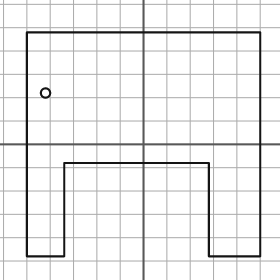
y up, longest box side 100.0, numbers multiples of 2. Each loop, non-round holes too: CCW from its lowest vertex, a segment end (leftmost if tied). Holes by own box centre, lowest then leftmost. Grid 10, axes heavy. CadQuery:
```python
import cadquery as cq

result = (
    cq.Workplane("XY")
    .moveTo(-50.0, -48.0)
    .lineTo(-34.0, -48.0)
    .lineTo(-34.0, -8.0)
    .lineTo(28.0, -8.0)
    .lineTo(28.0, -48.0)
    .lineTo(50.0, -48.0)
    .lineTo(50.0, 48.0)
    .lineTo(-50.0, 48.0)
    .close()
    .moveTo(-42.0, 22.0)
    .circle(2.0)
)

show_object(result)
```